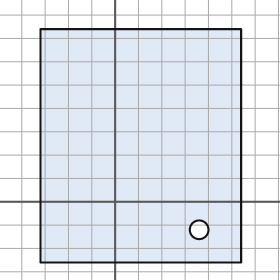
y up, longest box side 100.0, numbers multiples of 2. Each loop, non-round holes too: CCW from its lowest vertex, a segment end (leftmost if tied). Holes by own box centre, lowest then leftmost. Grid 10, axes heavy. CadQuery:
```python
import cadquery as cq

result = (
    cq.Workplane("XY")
    .moveTo(-32.0, -26.0)
    .lineTo(54.0, -26.0)
    .lineTo(54.0, 74.0)
    .lineTo(-32.0, 74.0)
    .close()
    .moveTo(36.0, -12.0)
    .circle(4.0)
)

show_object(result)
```